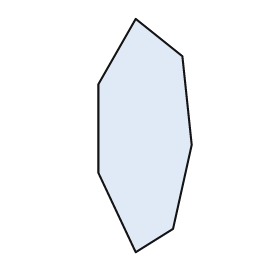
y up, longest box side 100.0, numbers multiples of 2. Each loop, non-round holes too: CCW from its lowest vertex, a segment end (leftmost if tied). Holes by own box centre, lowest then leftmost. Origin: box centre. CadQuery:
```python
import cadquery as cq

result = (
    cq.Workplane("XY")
    .moveTo(-4.0, -50.0)
    .lineTo(12.0, -40.0)
    .lineTo(20.0, -4.0)
    .lineTo(16.0, 34.0)
    .lineTo(-4.0, 50.0)
    .lineTo(-20.0, 22.0)
    .lineTo(-20.0, -16.0)
    .close()
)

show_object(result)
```